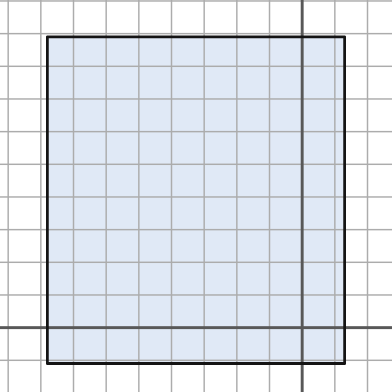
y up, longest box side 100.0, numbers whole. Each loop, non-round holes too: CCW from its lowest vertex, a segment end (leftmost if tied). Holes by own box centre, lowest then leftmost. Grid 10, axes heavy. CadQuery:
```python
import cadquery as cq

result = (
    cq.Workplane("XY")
    .moveTo(-78.0, -11.0)
    .lineTo(13.0, -11.0)
    .lineTo(13.0, 89.0)
    .lineTo(-78.0, 89.0)
    .close()
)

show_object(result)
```